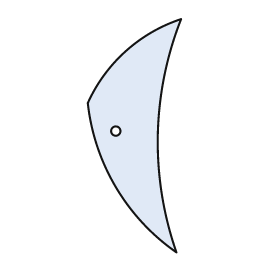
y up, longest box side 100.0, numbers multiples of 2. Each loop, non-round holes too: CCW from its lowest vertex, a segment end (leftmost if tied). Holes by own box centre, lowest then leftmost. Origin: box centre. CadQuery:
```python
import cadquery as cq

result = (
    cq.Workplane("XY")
    .moveTo(18.0, -50.0)
    .threePointArc((10.0, 0.0), (20.0, 50.0))
    .threePointArc((-4.0, 36.0), (-20.0, 14.0))
    .threePointArc((-8.0, -22.0), (18.0, -50.0))
    .close()
    .moveTo(-8.0, 2.0)
    .circle(2.0)
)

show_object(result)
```